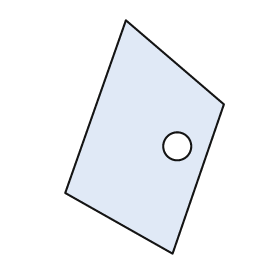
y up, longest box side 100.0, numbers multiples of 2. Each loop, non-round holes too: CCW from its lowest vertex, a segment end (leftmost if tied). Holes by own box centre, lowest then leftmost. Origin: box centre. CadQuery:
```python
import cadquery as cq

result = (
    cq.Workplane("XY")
    .moveTo(12.0, -50.0)
    .lineTo(34.0, 14.0)
    .lineTo(-8.0, 50.0)
    .lineTo(-34.0, -24.0)
    .close()
    .moveTo(14.0, -4.0)
    .circle(6.0)
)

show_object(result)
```